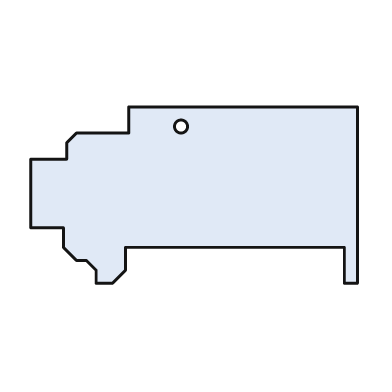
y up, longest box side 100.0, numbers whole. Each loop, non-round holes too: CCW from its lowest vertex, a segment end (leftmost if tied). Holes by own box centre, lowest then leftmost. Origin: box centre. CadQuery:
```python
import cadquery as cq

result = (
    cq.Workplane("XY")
    .moveTo(-30.0, -27.0)
    .lineTo(-25.0, -27.0)
    .lineTo(-21.0, -23.0)
    .lineTo(-21.0, -16.0)
    .lineTo(46.0, -16.0)
    .lineTo(46.0, -27.0)
    .lineTo(50.0, -27.0)
    .lineTo(50.0, 27.0)
    .lineTo(-20.0, 27.0)
    .lineTo(-20.0, 19.0)
    .lineTo(-36.0, 19.0)
    .lineTo(-39.0, 16.0)
    .lineTo(-39.0, 11.0)
    .lineTo(-50.0, 11.0)
    .lineTo(-50.0, -10.0)
    .lineTo(-40.0, -10.0)
    .lineTo(-40.0, -16.0)
    .lineTo(-36.0, -20.0)
    .lineTo(-33.0, -20.0)
    .lineTo(-30.0, -23.0)
    .close()
    .moveTo(-4.0, 21.0)
    .circle(2.0)
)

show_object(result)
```